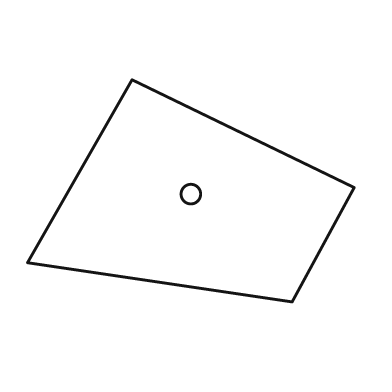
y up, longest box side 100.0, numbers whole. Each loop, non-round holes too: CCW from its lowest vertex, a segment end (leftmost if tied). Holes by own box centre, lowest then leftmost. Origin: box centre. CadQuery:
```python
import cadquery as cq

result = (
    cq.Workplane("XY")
    .moveTo(31.0, -34.0)
    .lineTo(50.0, 1.0)
    .lineTo(-18.0, 34.0)
    .lineTo(-50.0, -22.0)
    .close()
    .moveTo(0.0, -1.0)
    .circle(3.0)
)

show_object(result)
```